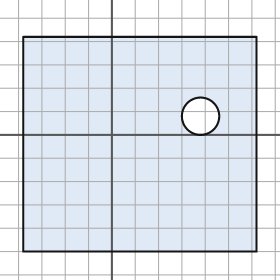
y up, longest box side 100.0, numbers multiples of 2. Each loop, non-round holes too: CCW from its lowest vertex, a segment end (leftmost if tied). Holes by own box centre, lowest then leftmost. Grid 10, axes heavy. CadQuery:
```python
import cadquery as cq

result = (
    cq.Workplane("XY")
    .moveTo(-38.0, -50.0)
    .lineTo(62.0, -50.0)
    .lineTo(62.0, 42.0)
    .lineTo(-38.0, 42.0)
    .close()
    .moveTo(38.0, 8.0)
    .circle(8.0)
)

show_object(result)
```